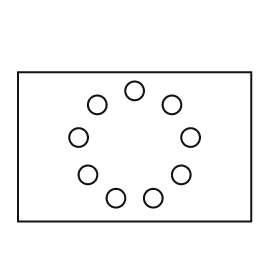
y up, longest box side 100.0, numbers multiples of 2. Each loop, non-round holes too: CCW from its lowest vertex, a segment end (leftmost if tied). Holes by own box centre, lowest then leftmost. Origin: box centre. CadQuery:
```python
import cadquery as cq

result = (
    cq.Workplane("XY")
    .moveTo(-50.0, -32.0)
    .lineTo(50.0, -32.0)
    .lineTo(50.0, 32.0)
    .lineTo(-50.0, 32.0)
    .close()
    .moveTo(-8.0, -22.0)
    .circle(4.0)
    .moveTo(8.0, -22.0)
    .circle(4.0)
    .moveTo(-20.0, -12.0)
    .circle(4.0)
    .moveTo(20.0, -12.0)
    .circle(4.0)
    .moveTo(-24.0, 4.0)
    .circle(4.0)
    .moveTo(24.0, 4.0)
    .circle(4.0)
    .moveTo(-16.0, 18.0)
    .circle(4.0)
    .moveTo(16.0, 18.0)
    .circle(4.0)
    .moveTo(0.0, 24.0)
    .circle(4.0)
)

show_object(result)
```